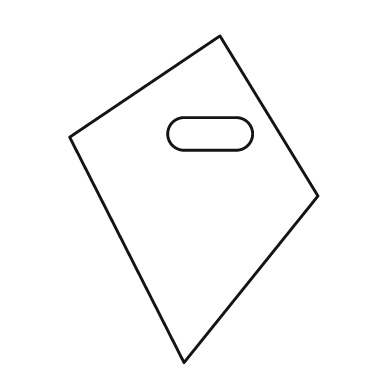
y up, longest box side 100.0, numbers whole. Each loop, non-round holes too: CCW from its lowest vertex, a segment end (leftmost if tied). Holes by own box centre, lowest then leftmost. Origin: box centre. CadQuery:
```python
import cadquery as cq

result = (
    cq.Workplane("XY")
    .moveTo(-3.0, -50.0)
    .lineTo(38.0, 1.0)
    .lineTo(8.0, 50.0)
    .lineTo(-38.0, 19.0)
    .close()
    .moveTo(-3.0, 15.0)
    .lineTo(13.0, 15.0)
    .threePointArc((18.0, 20.0), (13.0, 25.0))
    .lineTo(-3.0, 25.0)
    .threePointArc((-8.0, 20.0), (-3.0, 15.0))
    .close()
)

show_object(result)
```